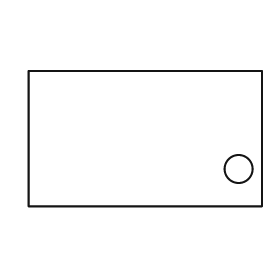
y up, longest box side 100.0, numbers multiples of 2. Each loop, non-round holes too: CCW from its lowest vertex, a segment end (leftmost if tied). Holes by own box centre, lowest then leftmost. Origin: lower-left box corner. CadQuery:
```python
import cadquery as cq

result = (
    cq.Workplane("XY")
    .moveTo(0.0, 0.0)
    .lineTo(100.0, 0.0)
    .lineTo(100.0, 58.0)
    .lineTo(0.0, 58.0)
    .close()
    .moveTo(90.0, 16.0)
    .circle(6.0)
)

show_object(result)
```